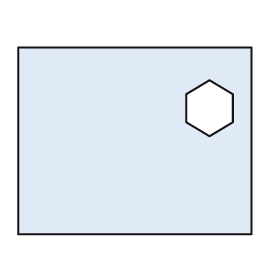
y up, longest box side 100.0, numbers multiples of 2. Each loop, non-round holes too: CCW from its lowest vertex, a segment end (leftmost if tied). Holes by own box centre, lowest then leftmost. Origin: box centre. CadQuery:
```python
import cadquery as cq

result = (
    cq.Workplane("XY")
    .moveTo(-50.0, -40.0)
    .lineTo(50.0, -40.0)
    .lineTo(50.0, 40.0)
    .lineTo(-50.0, 40.0)
    .close()
    .moveTo(32.0, 2.0)
    .lineTo(42.0, 8.0)
    .lineTo(42.0, 20.0)
    .lineTo(32.0, 26.0)
    .lineTo(22.0, 20.0)
    .lineTo(22.0, 8.0)
    .close()
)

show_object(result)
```